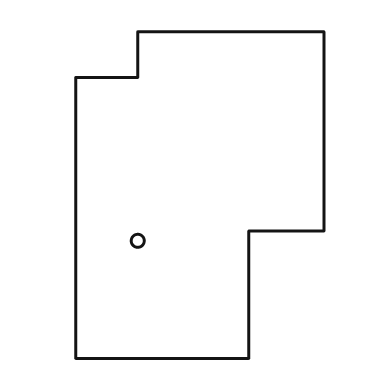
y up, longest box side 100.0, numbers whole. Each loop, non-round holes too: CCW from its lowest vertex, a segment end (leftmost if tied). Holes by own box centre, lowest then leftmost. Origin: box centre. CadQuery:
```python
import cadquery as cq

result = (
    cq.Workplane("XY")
    .moveTo(-38.0, -50.0)
    .lineTo(15.0, -50.0)
    .lineTo(15.0, -11.0)
    .lineTo(38.0, -11.0)
    .lineTo(38.0, 50.0)
    .lineTo(-19.0, 50.0)
    .lineTo(-19.0, 36.0)
    .lineTo(-38.0, 36.0)
    .close()
    .moveTo(-19.0, -14.0)
    .circle(2.0)
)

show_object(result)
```